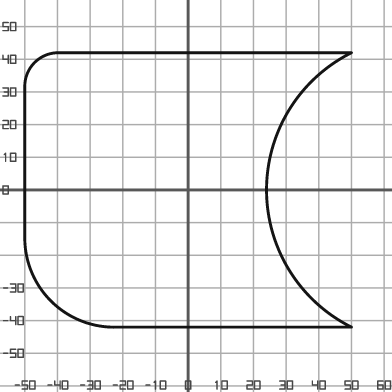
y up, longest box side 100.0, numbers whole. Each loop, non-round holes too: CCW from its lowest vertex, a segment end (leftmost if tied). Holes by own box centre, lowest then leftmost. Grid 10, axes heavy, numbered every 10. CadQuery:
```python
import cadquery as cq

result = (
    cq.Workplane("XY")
    .moveTo(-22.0, -42.0)
    .lineTo(50.0, -42.0)
    .threePointArc((24.0, 0.0), (50.0, 42.0))
    .lineTo(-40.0, 42.0)
    .threePointArc((-47.0, 39.0), (-50.0, 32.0))
    .lineTo(-50.0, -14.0)
    .threePointArc((-42.0, -34.0), (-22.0, -42.0))
    .close()
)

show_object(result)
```